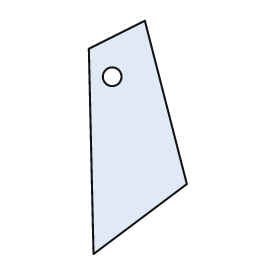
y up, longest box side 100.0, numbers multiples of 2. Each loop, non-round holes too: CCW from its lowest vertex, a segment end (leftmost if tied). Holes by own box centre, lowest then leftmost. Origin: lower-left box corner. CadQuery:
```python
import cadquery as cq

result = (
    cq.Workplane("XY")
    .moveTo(2.0, 0.0)
    .lineTo(42.0, 30.0)
    .lineTo(24.0, 100.0)
    .lineTo(0.0, 88.0)
    .close()
    .moveTo(10.0, 76.0)
    .circle(4.0)
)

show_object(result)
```